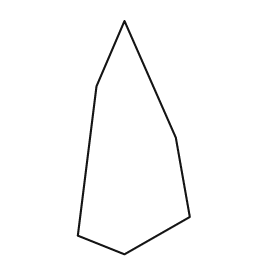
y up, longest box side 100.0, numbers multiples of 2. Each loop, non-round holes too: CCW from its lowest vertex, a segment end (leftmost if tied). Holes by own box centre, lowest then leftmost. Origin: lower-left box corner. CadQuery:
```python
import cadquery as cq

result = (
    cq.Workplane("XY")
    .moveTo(20.0, 0.0)
    .lineTo(48.0, 16.0)
    .lineTo(42.0, 50.0)
    .lineTo(20.0, 100.0)
    .lineTo(8.0, 72.0)
    .lineTo(0.0, 8.0)
    .close()
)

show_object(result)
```